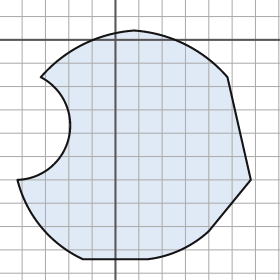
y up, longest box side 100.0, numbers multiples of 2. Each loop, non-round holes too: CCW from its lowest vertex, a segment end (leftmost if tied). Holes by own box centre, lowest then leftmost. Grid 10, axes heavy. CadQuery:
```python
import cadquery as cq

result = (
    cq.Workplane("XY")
    .moveTo(-14.0, -94.0)
    .lineTo(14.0, -94.0)
    .threePointArc((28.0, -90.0), (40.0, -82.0))
    .lineTo(58.0, -60.0)
    .lineTo(48.0, -16.0)
    .threePointArc((30.0, -2.0), (8.0, 4.0))
    .threePointArc((-14.0, -2.0), (-32.0, -16.0))
    .threePointArc((-20.0, -42.0), (-42.0, -60.0))
    .threePointArc((-32.0, -80.0), (-14.0, -94.0))
    .close()
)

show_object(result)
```